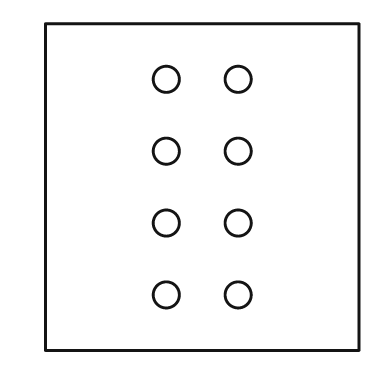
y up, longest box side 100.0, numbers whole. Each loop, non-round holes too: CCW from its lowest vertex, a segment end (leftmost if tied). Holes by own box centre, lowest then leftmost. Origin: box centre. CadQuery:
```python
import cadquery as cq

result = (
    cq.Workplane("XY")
    .moveTo(-48.0, -50.0)
    .lineTo(48.0, -50.0)
    .lineTo(48.0, 50.0)
    .lineTo(-48.0, 50.0)
    .close()
    .moveTo(-11.0, -33.0)
    .circle(4.0)
    .moveTo(11.0, -33.0)
    .circle(4.0)
    .moveTo(-11.0, -11.0)
    .circle(4.0)
    .moveTo(11.0, -11.0)
    .circle(4.0)
    .moveTo(-11.0, 11.0)
    .circle(4.0)
    .moveTo(11.0, 11.0)
    .circle(4.0)
    .moveTo(-11.0, 33.0)
    .circle(4.0)
    .moveTo(11.0, 33.0)
    .circle(4.0)
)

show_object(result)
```